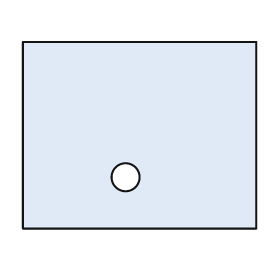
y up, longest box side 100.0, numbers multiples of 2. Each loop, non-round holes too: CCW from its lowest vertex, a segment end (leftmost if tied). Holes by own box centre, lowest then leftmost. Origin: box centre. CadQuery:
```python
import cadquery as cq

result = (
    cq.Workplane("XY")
    .moveTo(-50.0, -40.0)
    .lineTo(50.0, -40.0)
    .lineTo(50.0, 40.0)
    .lineTo(-50.0, 40.0)
    .close()
    .moveTo(-6.0, -18.0)
    .circle(6.0)
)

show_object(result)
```